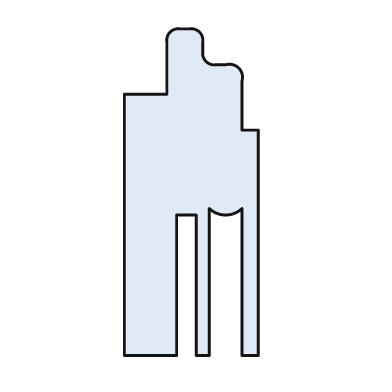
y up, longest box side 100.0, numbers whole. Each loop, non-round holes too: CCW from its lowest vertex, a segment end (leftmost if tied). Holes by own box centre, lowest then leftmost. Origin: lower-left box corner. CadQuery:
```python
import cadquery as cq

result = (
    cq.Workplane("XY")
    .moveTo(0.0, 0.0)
    .lineTo(16.0, 0.0)
    .lineTo(16.0, 43.0)
    .lineTo(22.0, 43.0)
    .lineTo(22.0, 0.0)
    .lineTo(26.0, 0.0)
    .lineTo(26.0, 45.0)
    .threePointArc((31.0, 43.0), (36.0, 45.0))
    .lineTo(36.0, 0.0)
    .lineTo(41.0, 0.0)
    .lineTo(41.0, 69.0)
    .lineTo(36.0, 69.0)
    .lineTo(36.0, 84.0)
    .threePointArc((35.0, 88.0), (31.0, 89.0))
    .lineTo(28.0, 89.0)
    .threePointArc((25.0, 90.0), (24.0, 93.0))
    .lineTo(24.0, 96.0)
    .threePointArc((23.0, 99.0), (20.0, 100.0))
    .lineTo(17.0, 100.0)
    .threePointArc((14.0, 99.0), (13.0, 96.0))
    .lineTo(13.0, 80.0)
    .lineTo(0.0, 80.0)
    .close()
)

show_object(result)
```